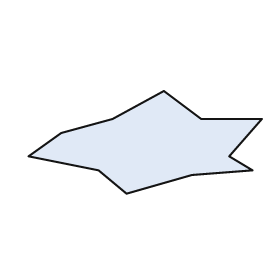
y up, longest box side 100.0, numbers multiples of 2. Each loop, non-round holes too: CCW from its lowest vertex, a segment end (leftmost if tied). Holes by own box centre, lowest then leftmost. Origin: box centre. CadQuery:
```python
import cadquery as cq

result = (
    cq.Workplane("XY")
    .moveTo(-8.0, -22.0)
    .lineTo(20.0, -14.0)
    .lineTo(46.0, -12.0)
    .lineTo(36.0, -6.0)
    .lineTo(50.0, 10.0)
    .lineTo(24.0, 10.0)
    .lineTo(8.0, 22.0)
    .lineTo(-14.0, 10.0)
    .lineTo(-36.0, 4.0)
    .lineTo(-50.0, -6.0)
    .lineTo(-20.0, -12.0)
    .close()
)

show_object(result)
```